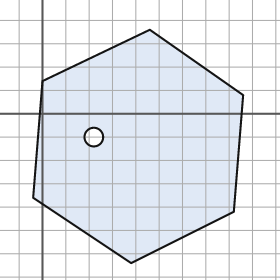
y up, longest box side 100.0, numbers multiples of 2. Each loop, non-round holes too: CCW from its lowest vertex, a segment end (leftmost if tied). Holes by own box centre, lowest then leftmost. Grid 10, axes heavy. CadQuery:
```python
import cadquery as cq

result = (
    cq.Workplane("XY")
    .moveTo(38.0, -64.0)
    .lineTo(82.0, -42.0)
    .lineTo(86.0, 8.0)
    .lineTo(46.0, 36.0)
    .lineTo(0.0, 14.0)
    .lineTo(-4.0, -36.0)
    .close()
    .moveTo(22.0, -10.0)
    .circle(4.0)
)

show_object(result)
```